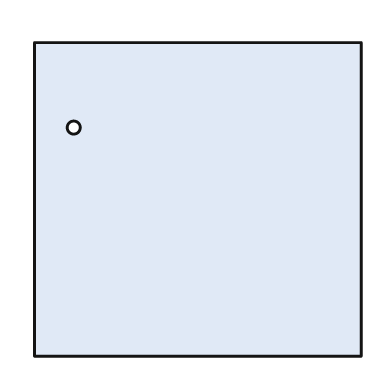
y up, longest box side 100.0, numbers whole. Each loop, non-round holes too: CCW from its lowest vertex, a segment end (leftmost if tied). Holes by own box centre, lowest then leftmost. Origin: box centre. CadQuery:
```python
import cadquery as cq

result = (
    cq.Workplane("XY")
    .moveTo(-50.0, -48.0)
    .lineTo(50.0, -48.0)
    .lineTo(50.0, 48.0)
    .lineTo(-50.0, 48.0)
    .close()
    .moveTo(-38.0, 22.0)
    .circle(2.0)
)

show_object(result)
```